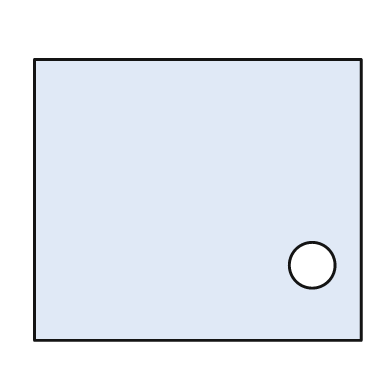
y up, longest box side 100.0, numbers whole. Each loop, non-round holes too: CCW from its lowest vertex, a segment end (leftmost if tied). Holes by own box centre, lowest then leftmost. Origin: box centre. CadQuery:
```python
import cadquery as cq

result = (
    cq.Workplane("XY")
    .moveTo(-50.0, -43.0)
    .lineTo(50.0, -43.0)
    .lineTo(50.0, 43.0)
    .lineTo(-50.0, 43.0)
    .close()
    .moveTo(35.0, -20.0)
    .circle(7.0)
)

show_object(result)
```